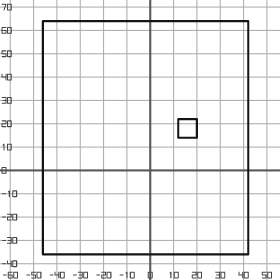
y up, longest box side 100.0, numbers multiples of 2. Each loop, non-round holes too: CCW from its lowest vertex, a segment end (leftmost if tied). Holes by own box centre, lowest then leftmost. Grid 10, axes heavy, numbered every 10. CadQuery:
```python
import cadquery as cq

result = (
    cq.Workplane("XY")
    .moveTo(-46.0, -36.0)
    .lineTo(42.0, -36.0)
    .lineTo(42.0, 64.0)
    .lineTo(-46.0, 64.0)
    .close()
    .moveTo(12.0, 14.0)
    .lineTo(20.0, 14.0)
    .lineTo(20.0, 22.0)
    .lineTo(12.0, 22.0)
    .close()
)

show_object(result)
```